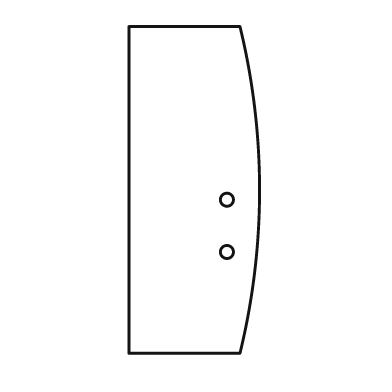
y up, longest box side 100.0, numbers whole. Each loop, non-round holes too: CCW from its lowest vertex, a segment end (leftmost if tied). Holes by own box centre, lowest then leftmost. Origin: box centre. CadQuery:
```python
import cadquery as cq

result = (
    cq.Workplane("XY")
    .moveTo(-20.0, -50.0)
    .lineTo(14.0, -50.0)
    .threePointArc((20.0, 0.0), (14.0, 50.0))
    .lineTo(-20.0, 50.0)
    .close()
    .moveTo(10.0, -19.0)
    .circle(2.0)
    .moveTo(10.0, -3.0)
    .circle(2.0)
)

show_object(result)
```